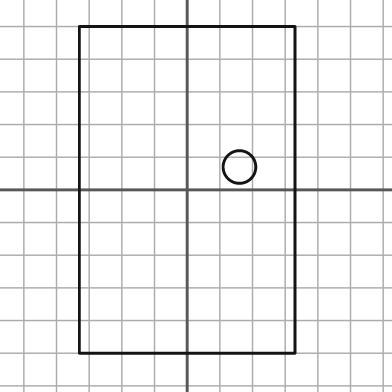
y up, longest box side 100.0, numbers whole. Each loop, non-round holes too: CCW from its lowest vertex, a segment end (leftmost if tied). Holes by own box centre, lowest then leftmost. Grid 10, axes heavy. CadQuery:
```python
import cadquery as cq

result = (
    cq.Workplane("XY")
    .moveTo(-33.0, -50.0)
    .lineTo(33.0, -50.0)
    .lineTo(33.0, 50.0)
    .lineTo(-33.0, 50.0)
    .close()
    .moveTo(16.0, 7.0)
    .circle(5.0)
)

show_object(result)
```